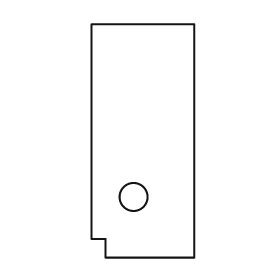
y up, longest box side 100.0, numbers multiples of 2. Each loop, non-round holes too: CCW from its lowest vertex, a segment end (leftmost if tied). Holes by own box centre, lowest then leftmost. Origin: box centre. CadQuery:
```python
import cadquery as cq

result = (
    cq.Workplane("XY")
    .moveTo(-16.0, -50.0)
    .lineTo(22.0, -50.0)
    .lineTo(22.0, 50.0)
    .lineTo(-22.0, 50.0)
    .lineTo(-22.0, -42.0)
    .lineTo(-16.0, -42.0)
    .close()
    .moveTo(-4.0, -24.0)
    .circle(6.0)
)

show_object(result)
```